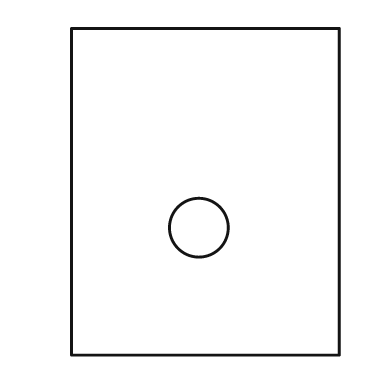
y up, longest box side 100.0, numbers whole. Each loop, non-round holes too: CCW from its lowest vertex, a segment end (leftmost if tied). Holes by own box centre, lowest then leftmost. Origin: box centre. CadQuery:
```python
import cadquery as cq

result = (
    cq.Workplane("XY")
    .moveTo(-41.0, -50.0)
    .lineTo(41.0, -50.0)
    .lineTo(41.0, 50.0)
    .lineTo(-41.0, 50.0)
    .close()
    .moveTo(-2.0, -11.0)
    .circle(9.0)
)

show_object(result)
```